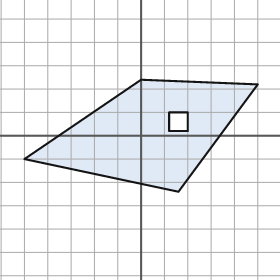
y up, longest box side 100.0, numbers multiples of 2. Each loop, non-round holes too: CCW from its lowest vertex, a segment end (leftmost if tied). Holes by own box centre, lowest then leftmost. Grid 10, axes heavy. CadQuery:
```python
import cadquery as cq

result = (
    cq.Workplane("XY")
    .moveTo(16.0, -24.0)
    .lineTo(50.0, 22.0)
    .lineTo(0.0, 24.0)
    .lineTo(-50.0, -10.0)
    .close()
    .moveTo(12.0, 2.0)
    .lineTo(20.0, 2.0)
    .lineTo(20.0, 10.0)
    .lineTo(12.0, 10.0)
    .close()
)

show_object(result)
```